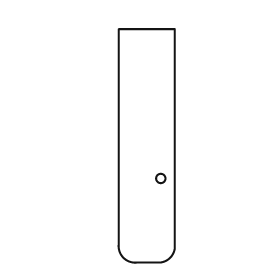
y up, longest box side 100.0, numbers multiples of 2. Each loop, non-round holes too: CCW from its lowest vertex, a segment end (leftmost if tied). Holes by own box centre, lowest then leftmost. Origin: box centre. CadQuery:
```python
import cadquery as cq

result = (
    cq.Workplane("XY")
    .moveTo(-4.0, -50.0)
    .lineTo(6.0, -50.0)
    .threePointArc((10.0, -48.0), (12.0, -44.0))
    .lineTo(12.0, 50.0)
    .lineTo(-12.0, 50.0)
    .lineTo(-12.0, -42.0)
    .threePointArc((-10.0, -48.0), (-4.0, -50.0))
    .close()
    .moveTo(6.0, -14.0)
    .circle(2.0)
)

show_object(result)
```